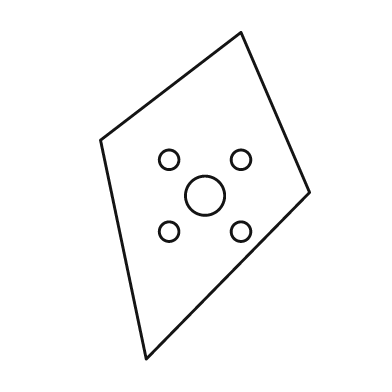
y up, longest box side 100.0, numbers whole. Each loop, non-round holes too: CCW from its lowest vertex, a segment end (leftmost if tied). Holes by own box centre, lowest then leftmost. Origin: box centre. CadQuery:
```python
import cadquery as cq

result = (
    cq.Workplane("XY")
    .moveTo(-18.0, -50.0)
    .lineTo(32.0, 1.0)
    .lineTo(11.0, 50.0)
    .lineTo(-32.0, 17.0)
    .close()
    .moveTo(-11.0, -11.0)
    .circle(3.0)
    .moveTo(11.0, -11.0)
    .circle(3.0)
    .moveTo(0.0, 0.0)
    .circle(6.0)
    .moveTo(-11.0, 11.0)
    .circle(3.0)
    .moveTo(11.0, 11.0)
    .circle(3.0)
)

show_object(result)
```